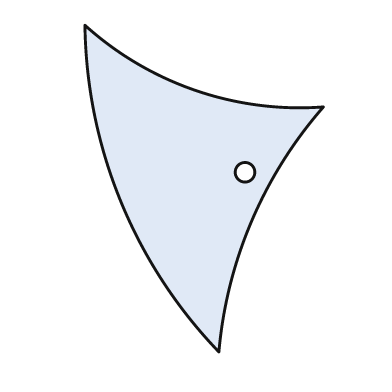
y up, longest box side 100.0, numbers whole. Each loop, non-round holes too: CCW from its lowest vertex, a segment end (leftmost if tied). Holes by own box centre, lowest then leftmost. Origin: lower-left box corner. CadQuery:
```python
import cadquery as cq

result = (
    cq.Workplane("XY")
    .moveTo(41.0, 0.0)
    .threePointArc((51.0, 40.0), (73.0, 75.0))
    .threePointArc((34.0, 80.0), (0.0, 100.0))
    .threePointArc((11.0, 46.0), (41.0, 0.0))
    .close()
    .moveTo(49.0, 55.0)
    .circle(3.0)
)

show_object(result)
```